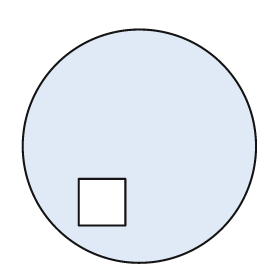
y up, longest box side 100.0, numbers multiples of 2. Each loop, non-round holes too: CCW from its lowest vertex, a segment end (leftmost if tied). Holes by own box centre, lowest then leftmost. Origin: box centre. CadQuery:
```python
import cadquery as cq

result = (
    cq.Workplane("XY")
    .moveTo(0.0, 0.0)
    .circle(50.0)
    .moveTo(-26.0, -34.0)
    .lineTo(-6.0, -34.0)
    .lineTo(-6.0, -14.0)
    .lineTo(-26.0, -14.0)
    .close()
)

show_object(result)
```